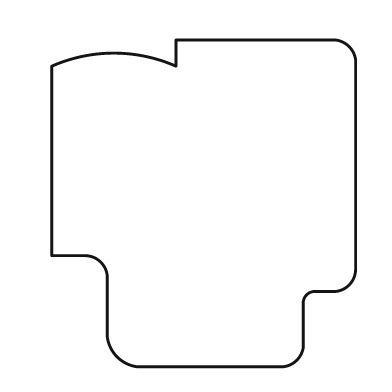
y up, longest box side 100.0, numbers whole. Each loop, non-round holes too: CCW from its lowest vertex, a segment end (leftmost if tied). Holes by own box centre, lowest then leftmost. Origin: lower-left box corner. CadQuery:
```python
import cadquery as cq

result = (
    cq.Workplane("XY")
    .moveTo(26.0, 0.0)
    .lineTo(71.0, 0.0)
    .threePointArc((75.0, 2.0), (77.0, 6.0))
    .lineTo(77.0, 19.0)
    .threePointArc((78.0, 22.0), (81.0, 23.0))
    .lineTo(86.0, 23.0)
    .threePointArc((91.0, 25.0), (93.0, 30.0))
    .lineTo(93.0, 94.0)
    .threePointArc((91.0, 98.0), (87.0, 100.0))
    .lineTo(38.0, 100.0)
    .lineTo(38.0, 92.0)
    .threePointArc((19.0, 96.0), (0.0, 92.0))
    .lineTo(0.0, 34.0)
    .lineTo(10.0, 34.0)
    .threePointArc((15.0, 32.0), (17.0, 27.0))
    .lineTo(17.0, 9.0)
    .threePointArc((20.0, 3.0), (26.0, 0.0))
    .close()
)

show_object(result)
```